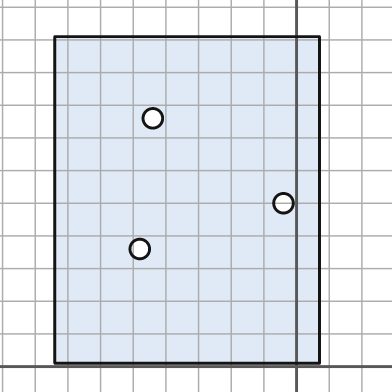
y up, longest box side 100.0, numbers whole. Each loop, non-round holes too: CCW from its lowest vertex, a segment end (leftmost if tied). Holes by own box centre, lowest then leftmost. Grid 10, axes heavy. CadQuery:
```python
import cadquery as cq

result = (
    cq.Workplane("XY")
    .moveTo(-74.0, 1.0)
    .lineTo(7.0, 1.0)
    .lineTo(7.0, 101.0)
    .lineTo(-74.0, 101.0)
    .close()
    .moveTo(-48.0, 36.0)
    .circle(3.0)
    .moveTo(-4.0, 50.0)
    .circle(3.0)
    .moveTo(-44.0, 76.0)
    .circle(3.0)
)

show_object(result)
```